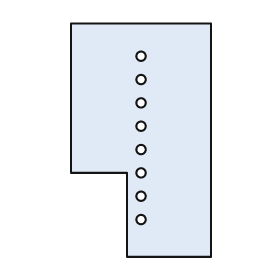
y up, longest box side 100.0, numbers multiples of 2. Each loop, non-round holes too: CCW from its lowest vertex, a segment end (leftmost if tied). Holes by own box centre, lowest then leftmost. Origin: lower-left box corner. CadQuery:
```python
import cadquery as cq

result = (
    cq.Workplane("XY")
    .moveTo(24.0, 0.0)
    .lineTo(60.0, 0.0)
    .lineTo(60.0, 100.0)
    .lineTo(0.0, 100.0)
    .lineTo(0.0, 36.0)
    .lineTo(24.0, 36.0)
    .close()
    .moveTo(30.0, 16.0)
    .circle(2.0)
    .moveTo(30.0, 26.0)
    .circle(2.0)
    .moveTo(30.0, 36.0)
    .circle(2.0)
    .moveTo(30.0, 46.0)
    .circle(2.0)
    .moveTo(30.0, 56.0)
    .circle(2.0)
    .moveTo(30.0, 66.0)
    .circle(2.0)
    .moveTo(30.0, 76.0)
    .circle(2.0)
    .moveTo(30.0, 86.0)
    .circle(2.0)
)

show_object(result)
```